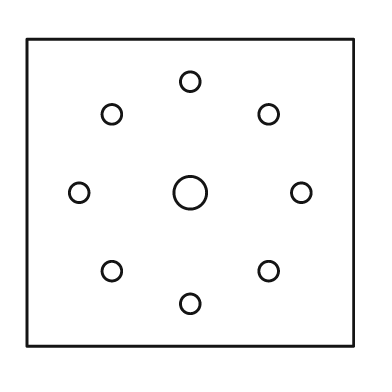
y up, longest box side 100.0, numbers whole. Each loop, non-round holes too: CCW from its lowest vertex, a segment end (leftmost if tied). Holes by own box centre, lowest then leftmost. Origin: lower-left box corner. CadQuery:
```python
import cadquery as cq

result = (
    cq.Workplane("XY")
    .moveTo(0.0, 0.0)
    .lineTo(100.0, 0.0)
    .lineTo(100.0, 94.0)
    .lineTo(0.0, 94.0)
    .close()
    .moveTo(50.0, 13.0)
    .circle(3.0)
    .moveTo(26.0, 23.0)
    .circle(3.0)
    .moveTo(74.0, 23.0)
    .circle(3.0)
    .moveTo(16.0, 47.0)
    .circle(3.0)
    .moveTo(50.0, 47.0)
    .circle(5.0)
    .moveTo(84.0, 47.0)
    .circle(3.0)
    .moveTo(26.0, 71.0)
    .circle(3.0)
    .moveTo(74.0, 71.0)
    .circle(3.0)
    .moveTo(50.0, 81.0)
    .circle(3.0)
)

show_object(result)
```